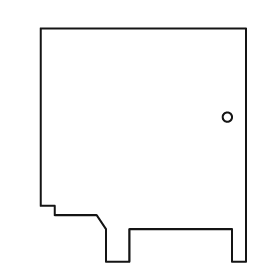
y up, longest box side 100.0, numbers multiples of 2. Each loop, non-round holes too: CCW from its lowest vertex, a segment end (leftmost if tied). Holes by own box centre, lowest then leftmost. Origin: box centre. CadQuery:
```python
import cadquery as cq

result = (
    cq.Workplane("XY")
    .moveTo(-16.0, -50.0)
    .lineTo(-6.0, -50.0)
    .lineTo(-6.0, -36.0)
    .lineTo(38.0, -36.0)
    .lineTo(38.0, -50.0)
    .lineTo(44.0, -50.0)
    .lineTo(44.0, 50.0)
    .lineTo(-44.0, 50.0)
    .lineTo(-44.0, -26.0)
    .lineTo(-38.0, -26.0)
    .lineTo(-38.0, -30.0)
    .lineTo(-20.0, -30.0)
    .lineTo(-16.0, -36.0)
    .close()
    .moveTo(36.0, 12.0)
    .circle(2.0)
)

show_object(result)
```